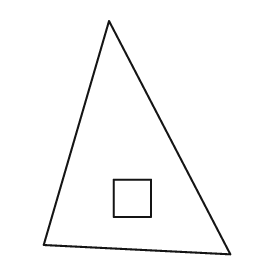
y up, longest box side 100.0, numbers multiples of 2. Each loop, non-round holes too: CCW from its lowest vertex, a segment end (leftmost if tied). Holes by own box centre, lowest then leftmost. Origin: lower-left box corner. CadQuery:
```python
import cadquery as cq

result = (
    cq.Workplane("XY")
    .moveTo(80.0, 0.0)
    .lineTo(28.0, 100.0)
    .lineTo(0.0, 4.0)
    .close()
    .moveTo(30.0, 16.0)
    .lineTo(46.0, 16.0)
    .lineTo(46.0, 32.0)
    .lineTo(30.0, 32.0)
    .close()
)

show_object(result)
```